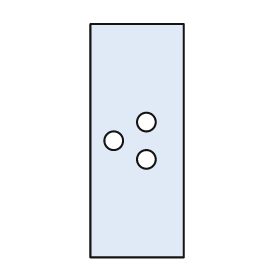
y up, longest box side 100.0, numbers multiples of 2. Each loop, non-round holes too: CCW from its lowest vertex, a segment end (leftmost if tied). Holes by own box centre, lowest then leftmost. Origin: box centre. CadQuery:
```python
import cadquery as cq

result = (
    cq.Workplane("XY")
    .moveTo(-20.0, -50.0)
    .lineTo(20.0, -50.0)
    .lineTo(20.0, 50.0)
    .lineTo(-20.0, 50.0)
    .close()
    .moveTo(4.0, -8.0)
    .circle(4.0)
    .moveTo(-10.0, 0.0)
    .circle(4.0)
    .moveTo(4.0, 8.0)
    .circle(4.0)
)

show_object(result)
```